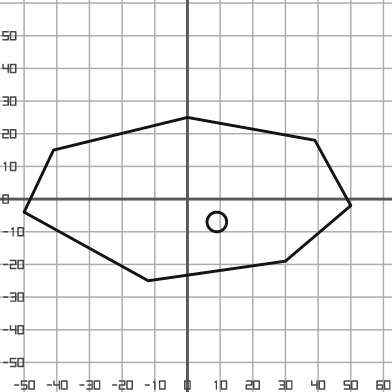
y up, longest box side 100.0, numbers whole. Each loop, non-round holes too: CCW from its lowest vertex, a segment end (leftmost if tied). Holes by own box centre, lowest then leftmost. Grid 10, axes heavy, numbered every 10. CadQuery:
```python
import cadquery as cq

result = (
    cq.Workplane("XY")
    .moveTo(-12.0, -25.0)
    .lineTo(30.0, -19.0)
    .lineTo(50.0, -2.0)
    .lineTo(39.0, 18.0)
    .lineTo(0.0, 25.0)
    .lineTo(-41.0, 15.0)
    .lineTo(-50.0, -4.0)
    .close()
    .moveTo(9.0, -7.0)
    .circle(3.0)
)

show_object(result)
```